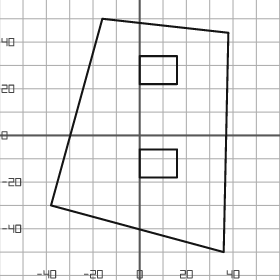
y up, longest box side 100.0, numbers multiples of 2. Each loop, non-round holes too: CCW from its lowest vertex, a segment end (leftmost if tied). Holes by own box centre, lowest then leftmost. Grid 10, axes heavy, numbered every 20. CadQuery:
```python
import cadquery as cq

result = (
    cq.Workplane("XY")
    .moveTo(36.0, -50.0)
    .lineTo(38.0, 44.0)
    .lineTo(-16.0, 50.0)
    .lineTo(-38.0, -30.0)
    .close()
    .moveTo(0.0, -18.0)
    .lineTo(16.0, -18.0)
    .lineTo(16.0, -6.0)
    .lineTo(0.0, -6.0)
    .close()
    .moveTo(0.0, 22.0)
    .lineTo(16.0, 22.0)
    .lineTo(16.0, 34.0)
    .lineTo(0.0, 34.0)
    .close()
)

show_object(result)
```